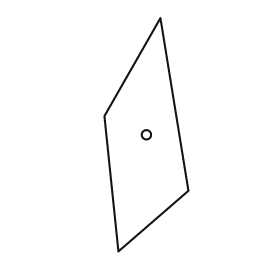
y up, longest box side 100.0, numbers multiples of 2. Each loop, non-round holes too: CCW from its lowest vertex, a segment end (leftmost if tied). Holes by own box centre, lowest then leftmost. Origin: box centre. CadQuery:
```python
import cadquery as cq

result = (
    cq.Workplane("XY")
    .moveTo(-12.0, -50.0)
    .lineTo(18.0, -24.0)
    .lineTo(6.0, 50.0)
    .lineTo(-18.0, 8.0)
    .close()
    .moveTo(0.0, 0.0)
    .circle(2.0)
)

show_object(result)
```